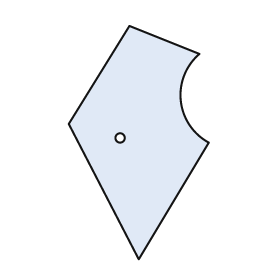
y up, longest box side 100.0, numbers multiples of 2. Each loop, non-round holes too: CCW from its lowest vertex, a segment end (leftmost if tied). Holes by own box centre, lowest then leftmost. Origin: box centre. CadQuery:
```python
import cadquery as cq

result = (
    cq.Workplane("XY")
    .moveTo(0.0, -50.0)
    .lineTo(30.0, 0.0)
    .threePointArc((18.0, 18.0), (26.0, 38.0))
    .lineTo(-4.0, 50.0)
    .lineTo(-30.0, 8.0)
    .close()
    .moveTo(-8.0, 2.0)
    .circle(2.0)
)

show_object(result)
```